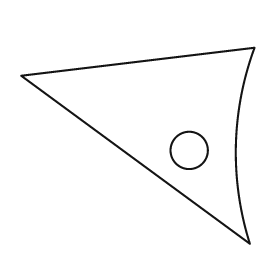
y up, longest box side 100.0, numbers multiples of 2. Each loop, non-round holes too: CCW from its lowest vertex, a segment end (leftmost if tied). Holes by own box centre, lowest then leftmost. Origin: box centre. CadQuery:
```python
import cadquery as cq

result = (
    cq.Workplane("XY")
    .moveTo(48.0, -42.0)
    .threePointArc((42.0, 0.0), (50.0, 42.0))
    .lineTo(-50.0, 30.0)
    .close()
    .moveTo(22.0, -2.0)
    .circle(8.0)
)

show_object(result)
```